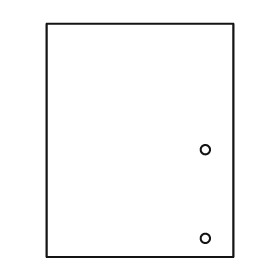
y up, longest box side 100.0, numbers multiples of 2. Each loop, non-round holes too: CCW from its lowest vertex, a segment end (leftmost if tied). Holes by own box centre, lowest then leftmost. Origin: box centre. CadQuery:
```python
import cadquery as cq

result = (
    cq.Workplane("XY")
    .moveTo(-40.0, -50.0)
    .lineTo(40.0, -50.0)
    .lineTo(40.0, 50.0)
    .lineTo(-40.0, 50.0)
    .close()
    .moveTo(28.0, -42.0)
    .circle(2.0)
    .moveTo(28.0, -4.0)
    .circle(2.0)
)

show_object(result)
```